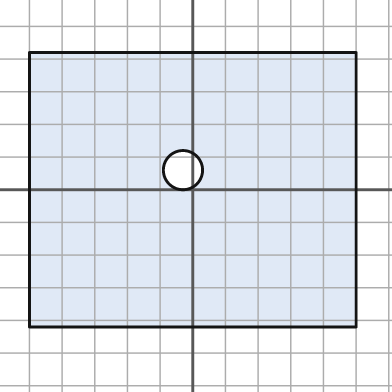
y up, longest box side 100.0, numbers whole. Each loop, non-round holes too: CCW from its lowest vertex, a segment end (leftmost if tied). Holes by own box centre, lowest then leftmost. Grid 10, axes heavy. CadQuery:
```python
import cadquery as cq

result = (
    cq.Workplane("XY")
    .moveTo(-50.0, -42.0)
    .lineTo(50.0, -42.0)
    .lineTo(50.0, 42.0)
    .lineTo(-50.0, 42.0)
    .close()
    .moveTo(-3.0, 6.0)
    .circle(6.0)
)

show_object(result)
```